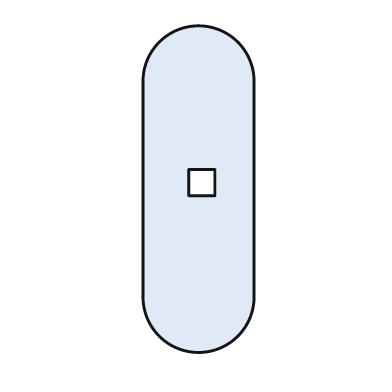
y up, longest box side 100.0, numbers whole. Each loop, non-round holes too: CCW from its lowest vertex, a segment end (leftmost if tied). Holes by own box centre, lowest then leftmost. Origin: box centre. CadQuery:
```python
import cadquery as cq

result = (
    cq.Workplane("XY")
    .moveTo(-17.0, -33.0)
    .threePointArc((0.0, -50.0), (17.0, -33.0))
    .lineTo(17.0, 33.0)
    .threePointArc((0.0, 50.0), (-17.0, 33.0))
    .close()
    .moveTo(-3.0, -2.0)
    .lineTo(5.0, -2.0)
    .lineTo(5.0, 6.0)
    .lineTo(-3.0, 6.0)
    .close()
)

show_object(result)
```